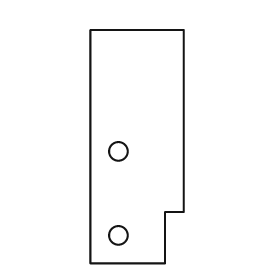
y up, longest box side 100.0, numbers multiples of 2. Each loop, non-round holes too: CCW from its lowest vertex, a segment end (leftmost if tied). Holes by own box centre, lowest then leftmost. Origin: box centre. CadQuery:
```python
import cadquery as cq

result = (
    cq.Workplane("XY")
    .moveTo(-20.0, -50.0)
    .lineTo(12.0, -50.0)
    .lineTo(12.0, -28.0)
    .lineTo(20.0, -28.0)
    .lineTo(20.0, 50.0)
    .lineTo(-20.0, 50.0)
    .close()
    .moveTo(-8.0, -38.0)
    .circle(4.0)
    .moveTo(-8.0, -2.0)
    .circle(4.0)
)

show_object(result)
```